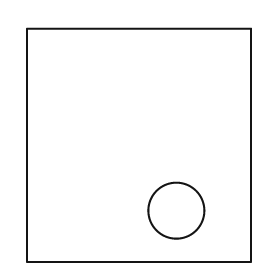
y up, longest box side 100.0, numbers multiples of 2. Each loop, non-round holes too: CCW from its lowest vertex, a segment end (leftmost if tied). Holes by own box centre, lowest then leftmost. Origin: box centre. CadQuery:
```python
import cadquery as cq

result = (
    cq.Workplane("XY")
    .moveTo(-48.0, -50.0)
    .lineTo(48.0, -50.0)
    .lineTo(48.0, 50.0)
    .lineTo(-48.0, 50.0)
    .close()
    .moveTo(16.0, -28.0)
    .circle(12.0)
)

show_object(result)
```